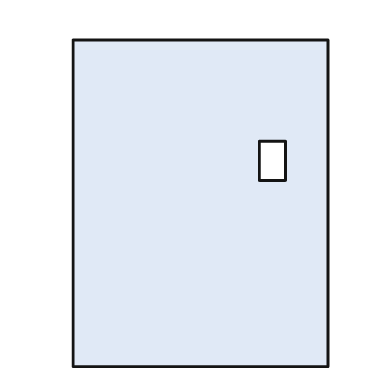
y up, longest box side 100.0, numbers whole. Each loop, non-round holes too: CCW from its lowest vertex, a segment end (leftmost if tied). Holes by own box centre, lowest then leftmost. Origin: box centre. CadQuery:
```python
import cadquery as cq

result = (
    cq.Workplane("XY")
    .moveTo(-39.0, -50.0)
    .lineTo(39.0, -50.0)
    .lineTo(39.0, 50.0)
    .lineTo(-39.0, 50.0)
    .close()
    .moveTo(18.0, 7.0)
    .lineTo(26.0, 7.0)
    .lineTo(26.0, 19.0)
    .lineTo(18.0, 19.0)
    .close()
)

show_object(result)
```